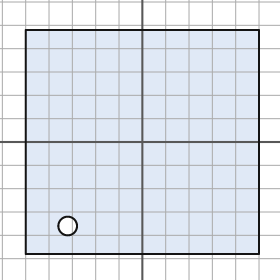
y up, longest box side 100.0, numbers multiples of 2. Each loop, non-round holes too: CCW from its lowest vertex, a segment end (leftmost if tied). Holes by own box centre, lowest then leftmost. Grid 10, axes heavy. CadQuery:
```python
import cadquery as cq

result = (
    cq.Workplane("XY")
    .moveTo(-50.0, -48.0)
    .lineTo(50.0, -48.0)
    .lineTo(50.0, 48.0)
    .lineTo(-50.0, 48.0)
    .close()
    .moveTo(-32.0, -36.0)
    .circle(4.0)
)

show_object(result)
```